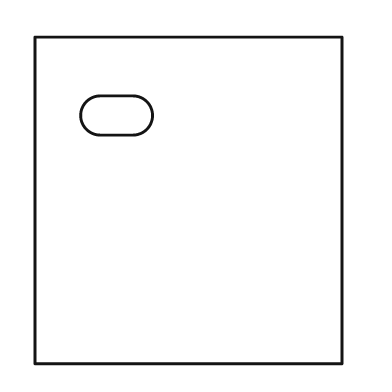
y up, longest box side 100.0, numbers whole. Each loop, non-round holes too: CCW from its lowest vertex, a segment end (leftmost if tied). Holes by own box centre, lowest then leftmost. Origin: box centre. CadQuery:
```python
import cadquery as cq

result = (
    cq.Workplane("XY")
    .moveTo(-47.0, -50.0)
    .lineTo(47.0, -50.0)
    .lineTo(47.0, 50.0)
    .lineTo(-47.0, 50.0)
    .close()
    .moveTo(-27.0, 20.0)
    .lineTo(-17.0, 20.0)
    .threePointArc((-11.0, 26.0), (-17.0, 32.0))
    .lineTo(-27.0, 32.0)
    .threePointArc((-33.0, 26.0), (-27.0, 20.0))
    .close()
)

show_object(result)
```